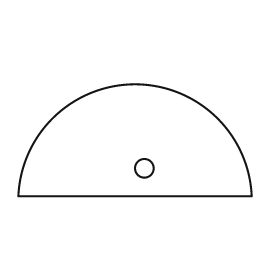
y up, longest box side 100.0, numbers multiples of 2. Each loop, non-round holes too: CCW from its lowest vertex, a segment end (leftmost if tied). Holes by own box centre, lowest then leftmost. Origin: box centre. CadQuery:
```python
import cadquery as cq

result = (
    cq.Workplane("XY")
    .moveTo(-50.0, -24.0)
    .lineTo(50.0, -24.0)
    .threePointArc((0.0, 24.0), (-50.0, -24.0))
    .close()
    .moveTo(4.0, -12.0)
    .circle(4.0)
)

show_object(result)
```